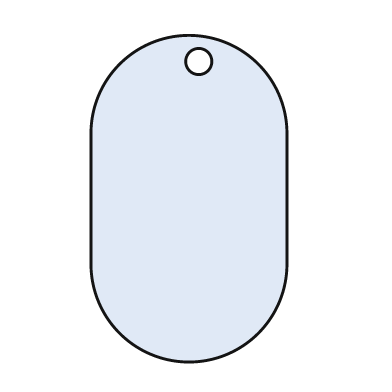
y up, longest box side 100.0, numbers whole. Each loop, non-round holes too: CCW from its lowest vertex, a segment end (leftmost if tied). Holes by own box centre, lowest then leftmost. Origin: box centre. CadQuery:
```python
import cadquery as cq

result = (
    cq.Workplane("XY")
    .moveTo(-30.0, -20.0)
    .threePointArc((0.0, -50.0), (30.0, -20.0))
    .lineTo(30.0, 20.0)
    .threePointArc((0.0, 50.0), (-30.0, 20.0))
    .close()
    .moveTo(3.0, 42.0)
    .circle(4.0)
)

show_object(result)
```